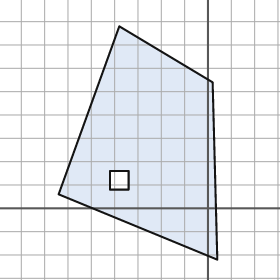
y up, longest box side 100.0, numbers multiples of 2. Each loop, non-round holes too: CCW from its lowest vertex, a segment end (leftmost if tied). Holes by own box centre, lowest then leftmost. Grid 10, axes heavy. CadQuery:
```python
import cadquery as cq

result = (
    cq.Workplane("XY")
    .moveTo(4.0, -22.0)
    .lineTo(2.0, 54.0)
    .lineTo(-38.0, 78.0)
    .lineTo(-64.0, 6.0)
    .close()
    .moveTo(-42.0, 8.0)
    .lineTo(-34.0, 8.0)
    .lineTo(-34.0, 16.0)
    .lineTo(-42.0, 16.0)
    .close()
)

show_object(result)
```